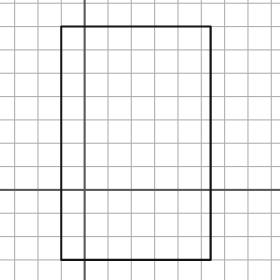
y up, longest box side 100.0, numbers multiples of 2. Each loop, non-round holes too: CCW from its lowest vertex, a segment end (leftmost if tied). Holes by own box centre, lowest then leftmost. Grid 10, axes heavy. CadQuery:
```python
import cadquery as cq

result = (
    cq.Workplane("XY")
    .moveTo(-10.0, -30.0)
    .lineTo(54.0, -30.0)
    .lineTo(54.0, 70.0)
    .lineTo(-10.0, 70.0)
    .close()
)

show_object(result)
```